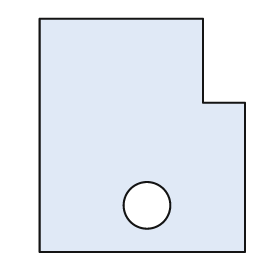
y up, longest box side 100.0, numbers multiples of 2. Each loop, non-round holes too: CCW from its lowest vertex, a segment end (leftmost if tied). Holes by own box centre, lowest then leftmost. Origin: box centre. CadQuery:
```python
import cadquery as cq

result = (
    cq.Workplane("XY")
    .moveTo(-44.0, -50.0)
    .lineTo(44.0, -50.0)
    .lineTo(44.0, 14.0)
    .lineTo(26.0, 14.0)
    .lineTo(26.0, 50.0)
    .lineTo(-44.0, 50.0)
    .close()
    .moveTo(2.0, -30.0)
    .circle(10.0)
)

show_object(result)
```